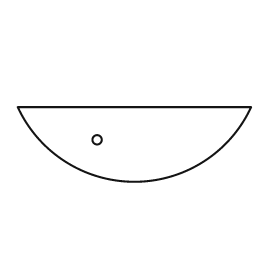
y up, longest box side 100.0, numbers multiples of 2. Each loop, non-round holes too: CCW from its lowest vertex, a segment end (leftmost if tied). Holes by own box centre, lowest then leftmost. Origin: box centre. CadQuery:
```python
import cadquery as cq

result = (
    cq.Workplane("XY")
    .moveTo(-50.0, 16.0)
    .threePointArc((0.0, -16.0), (50.0, 16.0))
    .close()
    .moveTo(-16.0, 2.0)
    .circle(2.0)
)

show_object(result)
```